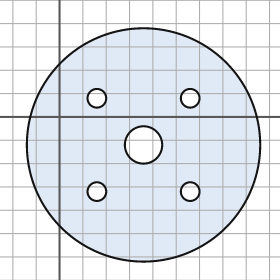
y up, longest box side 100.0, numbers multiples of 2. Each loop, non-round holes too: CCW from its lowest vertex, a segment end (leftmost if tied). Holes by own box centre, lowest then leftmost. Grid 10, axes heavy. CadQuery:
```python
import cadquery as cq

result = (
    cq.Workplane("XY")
    .moveTo(36.0, -12.0)
    .circle(50.0)
    .moveTo(16.0, -32.0)
    .circle(4.0)
    .moveTo(56.0, -32.0)
    .circle(4.0)
    .moveTo(36.0, -12.0)
    .circle(8.0)
    .moveTo(16.0, 8.0)
    .circle(4.0)
    .moveTo(56.0, 8.0)
    .circle(4.0)
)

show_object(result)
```